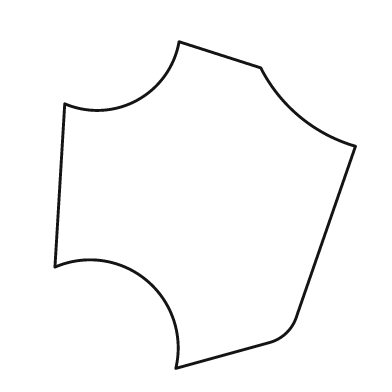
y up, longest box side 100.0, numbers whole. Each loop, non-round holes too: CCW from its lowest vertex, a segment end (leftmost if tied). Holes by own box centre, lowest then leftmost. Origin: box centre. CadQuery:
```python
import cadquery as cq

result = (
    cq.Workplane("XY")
    .moveTo(-9.0, -50.0)
    .lineTo(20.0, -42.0)
    .threePointArc((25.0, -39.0), (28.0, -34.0))
    .lineTo(46.0, 18.0)
    .threePointArc((29.0, 27.0), (17.0, 42.0))
    .lineTo(-8.0, 50.0)
    .threePointArc((-21.0, 32.0), (-43.0, 31.0))
    .lineTo(-46.0, -19.0)
    .threePointArc((-18.0, -23.0), (-9.0, -50.0))
    .close()
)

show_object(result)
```